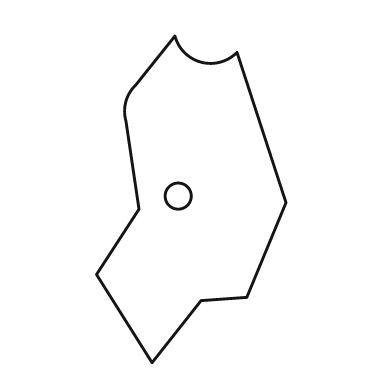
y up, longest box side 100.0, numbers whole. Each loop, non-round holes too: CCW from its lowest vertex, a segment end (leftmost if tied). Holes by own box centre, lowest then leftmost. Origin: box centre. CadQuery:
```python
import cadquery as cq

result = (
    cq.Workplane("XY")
    .moveTo(-12.0, -50.0)
    .lineTo(3.0, -31.0)
    .lineTo(17.0, -30.0)
    .lineTo(29.0, -1.0)
    .lineTo(14.0, 45.0)
    .threePointArc((3.0, 42.0), (-5.0, 50.0))
    .lineTo(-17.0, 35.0)
    .threePointArc((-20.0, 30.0), (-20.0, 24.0))
    .lineTo(-16.0, -3.0)
    .lineTo(-29.0, -23.0)
    .close()
    .moveTo(-4.0, 1.0)
    .circle(4.0)
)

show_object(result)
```